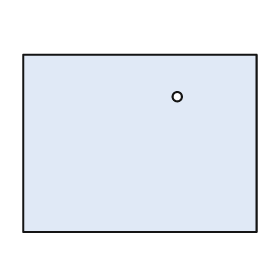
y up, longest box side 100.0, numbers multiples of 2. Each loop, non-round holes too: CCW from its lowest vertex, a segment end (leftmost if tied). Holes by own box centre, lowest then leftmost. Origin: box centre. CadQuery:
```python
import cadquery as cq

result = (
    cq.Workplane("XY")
    .moveTo(-50.0, -38.0)
    .lineTo(50.0, -38.0)
    .lineTo(50.0, 38.0)
    .lineTo(-50.0, 38.0)
    .close()
    .moveTo(16.0, 20.0)
    .circle(2.0)
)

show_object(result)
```